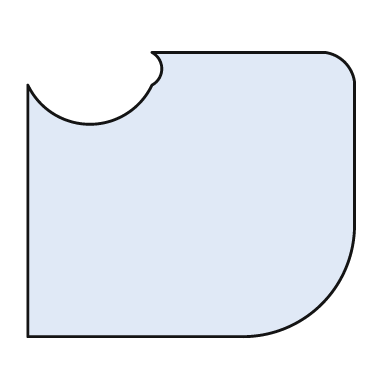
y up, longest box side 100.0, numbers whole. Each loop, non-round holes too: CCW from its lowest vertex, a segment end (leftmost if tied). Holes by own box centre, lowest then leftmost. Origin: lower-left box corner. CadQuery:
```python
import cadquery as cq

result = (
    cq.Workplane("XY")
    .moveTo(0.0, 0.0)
    .lineTo(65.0, 0.0)
    .threePointArc((90.0, 10.0), (100.0, 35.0))
    .lineTo(100.0, 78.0)
    .threePointArc((97.0, 84.0), (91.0, 87.0))
    .lineTo(38.0, 87.0)
    .threePointArc((41.0, 82.0), (38.0, 77.0))
    .threePointArc((19.0, 65.0), (0.0, 77.0))
    .close()
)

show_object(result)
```